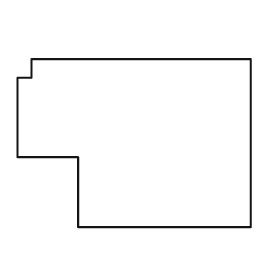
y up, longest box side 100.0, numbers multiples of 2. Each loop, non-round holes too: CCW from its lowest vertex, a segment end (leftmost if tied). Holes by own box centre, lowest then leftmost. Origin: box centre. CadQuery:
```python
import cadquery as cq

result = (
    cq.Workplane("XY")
    .moveTo(-24.0, -36.0)
    .lineTo(50.0, -36.0)
    .lineTo(50.0, 36.0)
    .lineTo(-44.0, 36.0)
    .lineTo(-44.0, 28.0)
    .lineTo(-50.0, 28.0)
    .lineTo(-50.0, -6.0)
    .lineTo(-24.0, -6.0)
    .close()
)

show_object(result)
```